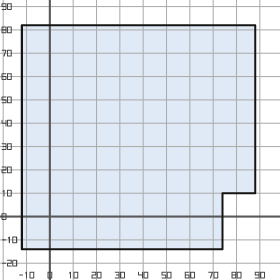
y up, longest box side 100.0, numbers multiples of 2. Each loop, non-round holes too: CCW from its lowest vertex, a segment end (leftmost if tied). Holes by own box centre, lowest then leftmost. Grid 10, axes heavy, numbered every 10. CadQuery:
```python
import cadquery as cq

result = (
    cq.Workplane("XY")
    .moveTo(-12.0, -14.0)
    .lineTo(74.0, -14.0)
    .lineTo(74.0, 10.0)
    .lineTo(88.0, 10.0)
    .lineTo(88.0, 82.0)
    .lineTo(-12.0, 82.0)
    .close()
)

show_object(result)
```